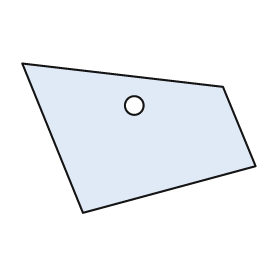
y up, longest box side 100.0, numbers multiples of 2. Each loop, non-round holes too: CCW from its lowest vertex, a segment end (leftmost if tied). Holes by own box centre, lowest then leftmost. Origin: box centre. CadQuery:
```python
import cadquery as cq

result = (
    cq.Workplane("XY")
    .moveTo(-24.0, -32.0)
    .lineTo(50.0, -12.0)
    .lineTo(36.0, 22.0)
    .lineTo(-50.0, 32.0)
    .close()
    .moveTo(-2.0, 14.0)
    .circle(4.0)
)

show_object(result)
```